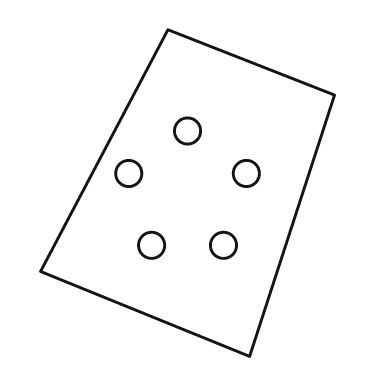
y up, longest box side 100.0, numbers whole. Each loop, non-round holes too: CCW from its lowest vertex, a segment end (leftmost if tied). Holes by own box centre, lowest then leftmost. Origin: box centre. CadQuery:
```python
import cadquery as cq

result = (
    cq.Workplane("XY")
    .moveTo(19.0, -50.0)
    .lineTo(45.0, 30.0)
    .lineTo(-6.0, 50.0)
    .lineTo(-45.0, -24.0)
    .close()
    .moveTo(-11.0, -16.0)
    .circle(4.0)
    .moveTo(11.0, -16.0)
    .circle(4.0)
    .moveTo(-18.0, 6.0)
    .circle(4.0)
    .moveTo(18.0, 6.0)
    .circle(4.0)
    .moveTo(0.0, 19.0)
    .circle(4.0)
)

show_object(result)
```